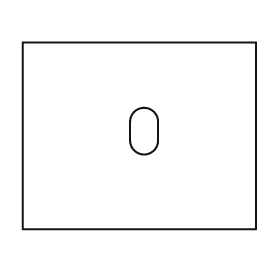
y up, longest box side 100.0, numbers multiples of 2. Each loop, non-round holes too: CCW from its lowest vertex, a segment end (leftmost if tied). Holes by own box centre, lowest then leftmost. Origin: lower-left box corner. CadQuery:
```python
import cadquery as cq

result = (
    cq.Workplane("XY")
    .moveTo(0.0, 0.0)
    .lineTo(100.0, 0.0)
    .lineTo(100.0, 80.0)
    .lineTo(0.0, 80.0)
    .close()
    .moveTo(46.0, 38.0)
    .threePointArc((52.0, 32.0), (58.0, 38.0))
    .lineTo(58.0, 46.0)
    .threePointArc((52.0, 52.0), (46.0, 46.0))
    .close()
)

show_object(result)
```